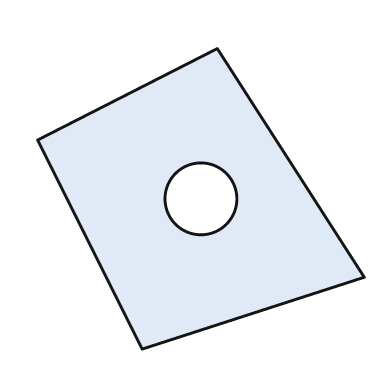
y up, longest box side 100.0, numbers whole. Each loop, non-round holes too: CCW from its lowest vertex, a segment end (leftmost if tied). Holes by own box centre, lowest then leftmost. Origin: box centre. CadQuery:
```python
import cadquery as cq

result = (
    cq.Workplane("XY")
    .moveTo(-18.0, -46.0)
    .lineTo(50.0, -24.0)
    .lineTo(5.0, 46.0)
    .lineTo(-50.0, 18.0)
    .close()
    .moveTo(0.0, 0.0)
    .circle(11.0)
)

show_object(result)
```